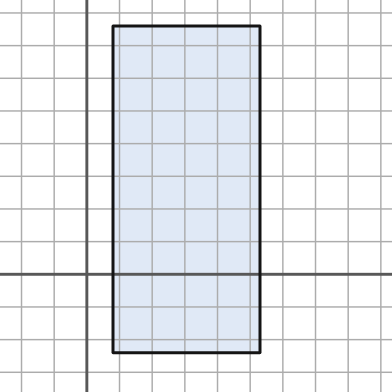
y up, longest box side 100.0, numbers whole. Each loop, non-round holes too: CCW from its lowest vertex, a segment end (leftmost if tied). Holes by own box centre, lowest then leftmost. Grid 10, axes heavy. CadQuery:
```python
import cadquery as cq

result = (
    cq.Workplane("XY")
    .moveTo(8.0, -24.0)
    .lineTo(53.0, -24.0)
    .lineTo(53.0, 76.0)
    .lineTo(8.0, 76.0)
    .close()
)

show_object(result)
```